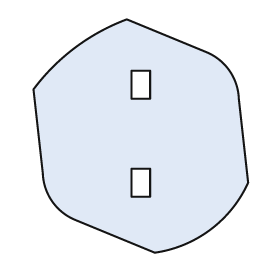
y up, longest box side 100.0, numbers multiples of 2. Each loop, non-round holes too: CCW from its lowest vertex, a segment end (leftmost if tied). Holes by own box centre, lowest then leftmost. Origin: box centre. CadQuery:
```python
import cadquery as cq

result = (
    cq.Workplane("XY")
    .moveTo(6.0, -50.0)
    .threePointArc((30.0, -40.0), (46.0, -20.0))
    .lineTo(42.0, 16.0)
    .threePointArc((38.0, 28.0), (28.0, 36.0))
    .lineTo(-6.0, 50.0)
    .threePointArc((-28.0, 38.0), (-46.0, 20.0))
    .lineTo(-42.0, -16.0)
    .threePointArc((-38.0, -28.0), (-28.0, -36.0))
    .close()
    .moveTo(-4.0, -26.0)
    .lineTo(4.0, -26.0)
    .lineTo(4.0, -14.0)
    .lineTo(-4.0, -14.0)
    .close()
    .moveTo(-4.0, 16.0)
    .lineTo(4.0, 16.0)
    .lineTo(4.0, 28.0)
    .lineTo(-4.0, 28.0)
    .close()
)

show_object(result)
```